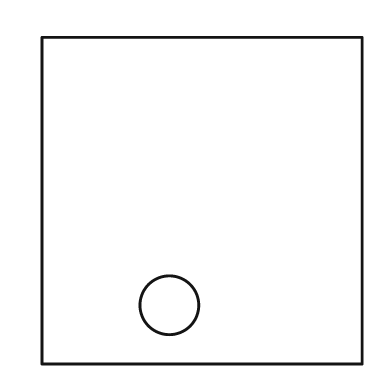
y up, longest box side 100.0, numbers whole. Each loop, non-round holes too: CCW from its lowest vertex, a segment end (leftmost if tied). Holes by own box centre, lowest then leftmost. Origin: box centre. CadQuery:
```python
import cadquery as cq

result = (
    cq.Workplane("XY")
    .moveTo(-49.0, -50.0)
    .lineTo(49.0, -50.0)
    .lineTo(49.0, 50.0)
    .lineTo(-49.0, 50.0)
    .close()
    .moveTo(-10.0, -32.0)
    .circle(9.0)
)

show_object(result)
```